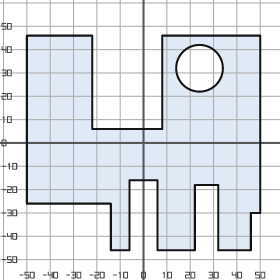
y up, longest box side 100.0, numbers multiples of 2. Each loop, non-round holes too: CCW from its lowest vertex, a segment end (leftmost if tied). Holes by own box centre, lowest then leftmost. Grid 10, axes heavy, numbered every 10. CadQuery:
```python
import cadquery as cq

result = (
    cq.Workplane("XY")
    .moveTo(-14.0, -46.0)
    .lineTo(-6.0, -46.0)
    .lineTo(-6.0, -16.0)
    .lineTo(6.0, -16.0)
    .lineTo(6.0, -46.0)
    .lineTo(22.0, -46.0)
    .lineTo(22.0, -18.0)
    .lineTo(32.0, -18.0)
    .lineTo(32.0, -46.0)
    .lineTo(46.0, -46.0)
    .lineTo(46.0, -30.0)
    .lineTo(50.0, -30.0)
    .lineTo(50.0, 46.0)
    .lineTo(8.0, 46.0)
    .lineTo(8.0, 6.0)
    .lineTo(-22.0, 6.0)
    .lineTo(-22.0, 46.0)
    .lineTo(-50.0, 46.0)
    .lineTo(-50.0, -26.0)
    .lineTo(-14.0, -26.0)
    .close()
    .moveTo(24.0, 32.0)
    .circle(10.0)
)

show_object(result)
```